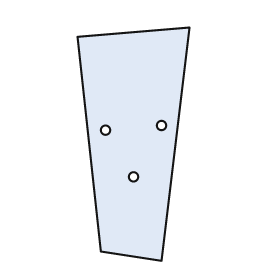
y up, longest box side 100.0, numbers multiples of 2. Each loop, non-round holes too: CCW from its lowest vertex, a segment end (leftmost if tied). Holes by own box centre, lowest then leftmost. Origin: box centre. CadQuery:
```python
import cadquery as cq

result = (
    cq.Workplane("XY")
    .moveTo(12.0, -50.0)
    .lineTo(24.0, 50.0)
    .lineTo(-24.0, 46.0)
    .lineTo(-14.0, -46.0)
    .close()
    .moveTo(0.0, -14.0)
    .circle(2.0)
    .moveTo(-12.0, 6.0)
    .circle(2.0)
    .moveTo(12.0, 8.0)
    .circle(2.0)
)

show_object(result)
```